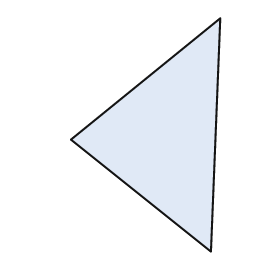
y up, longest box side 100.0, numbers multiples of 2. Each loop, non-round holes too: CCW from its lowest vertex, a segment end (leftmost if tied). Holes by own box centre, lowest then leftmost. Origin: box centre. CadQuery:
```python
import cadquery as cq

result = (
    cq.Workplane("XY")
    .moveTo(28.0, -50.0)
    .lineTo(32.0, 50.0)
    .lineTo(-32.0, -2.0)
    .close()
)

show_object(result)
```